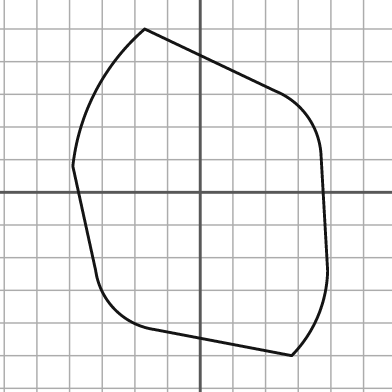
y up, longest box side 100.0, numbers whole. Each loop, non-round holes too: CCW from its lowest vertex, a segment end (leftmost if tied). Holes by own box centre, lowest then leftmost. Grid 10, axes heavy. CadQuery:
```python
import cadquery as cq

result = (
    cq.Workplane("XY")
    .moveTo(28.0, -50.0)
    .threePointArc((36.0, -38.0), (39.0, -24.0))
    .lineTo(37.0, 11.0)
    .threePointArc((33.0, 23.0), (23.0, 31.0))
    .lineTo(-17.0, 50.0)
    .threePointArc((-32.0, 31.0), (-39.0, 8.0))
    .lineTo(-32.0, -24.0)
    .threePointArc((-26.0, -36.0), (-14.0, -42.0))
    .close()
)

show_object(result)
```